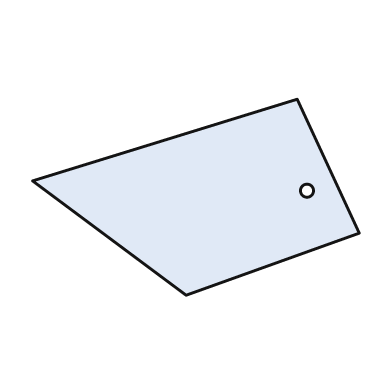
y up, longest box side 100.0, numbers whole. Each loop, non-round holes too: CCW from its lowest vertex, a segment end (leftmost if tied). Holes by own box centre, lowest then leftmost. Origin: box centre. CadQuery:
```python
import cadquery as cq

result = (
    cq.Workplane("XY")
    .moveTo(-3.0, -30.0)
    .lineTo(50.0, -11.0)
    .lineTo(31.0, 30.0)
    .lineTo(-50.0, 5.0)
    .close()
    .moveTo(34.0, 2.0)
    .circle(2.0)
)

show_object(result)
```